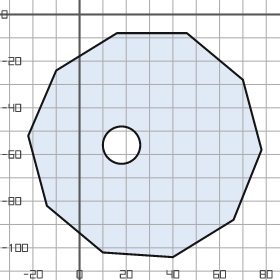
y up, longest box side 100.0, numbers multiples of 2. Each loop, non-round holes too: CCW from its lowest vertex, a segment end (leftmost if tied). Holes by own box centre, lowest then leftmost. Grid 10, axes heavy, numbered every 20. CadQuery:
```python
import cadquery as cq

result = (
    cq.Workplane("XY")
    .moveTo(40.0, -104.0)
    .lineTo(66.0, -88.0)
    .lineTo(78.0, -58.0)
    .lineTo(70.0, -28.0)
    .lineTo(46.0, -8.0)
    .lineTo(16.0, -8.0)
    .lineTo(-10.0, -24.0)
    .lineTo(-22.0, -52.0)
    .lineTo(-14.0, -82.0)
    .lineTo(10.0, -102.0)
    .close()
    .moveTo(18.0, -56.0)
    .circle(8.0)
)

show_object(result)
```